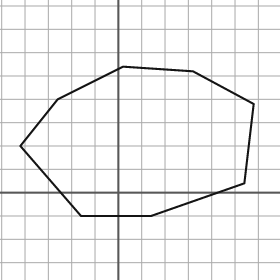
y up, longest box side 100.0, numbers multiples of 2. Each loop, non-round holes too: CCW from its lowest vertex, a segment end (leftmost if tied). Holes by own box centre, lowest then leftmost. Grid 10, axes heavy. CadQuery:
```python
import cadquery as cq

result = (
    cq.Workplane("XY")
    .moveTo(-16.0, -10.0)
    .lineTo(14.0, -10.0)
    .lineTo(54.0, 4.0)
    .lineTo(58.0, 38.0)
    .lineTo(32.0, 52.0)
    .lineTo(2.0, 54.0)
    .lineTo(-26.0, 40.0)
    .lineTo(-42.0, 20.0)
    .close()
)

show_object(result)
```